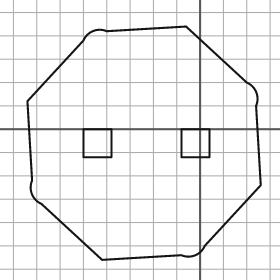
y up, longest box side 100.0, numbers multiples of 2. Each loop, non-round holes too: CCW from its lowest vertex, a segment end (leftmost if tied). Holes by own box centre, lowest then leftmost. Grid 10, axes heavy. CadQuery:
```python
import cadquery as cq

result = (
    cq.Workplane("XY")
    .moveTo(-42.0, -56.0)
    .lineTo(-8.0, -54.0)
    .threePointArc((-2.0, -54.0), (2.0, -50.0))
    .lineTo(26.0, -24.0)
    .lineTo(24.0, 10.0)
    .threePointArc((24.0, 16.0), (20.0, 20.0))
    .lineTo(-6.0, 44.0)
    .lineTo(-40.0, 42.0)
    .threePointArc((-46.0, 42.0), (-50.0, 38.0))
    .lineTo(-74.0, 12.0)
    .lineTo(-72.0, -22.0)
    .threePointArc((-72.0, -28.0), (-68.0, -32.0))
    .close()
    .moveTo(-50.0, -12.0)
    .lineTo(-38.0, -12.0)
    .lineTo(-38.0, 0.0)
    .lineTo(-50.0, 0.0)
    .close()
    .moveTo(-8.0, -12.0)
    .lineTo(4.0, -12.0)
    .lineTo(4.0, 0.0)
    .lineTo(-8.0, 0.0)
    .close()
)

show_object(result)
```